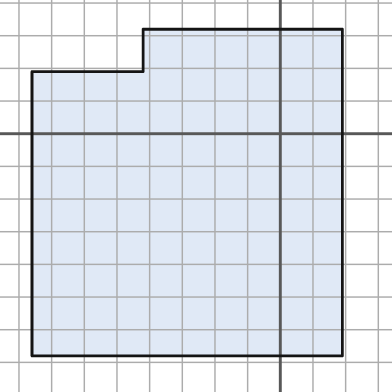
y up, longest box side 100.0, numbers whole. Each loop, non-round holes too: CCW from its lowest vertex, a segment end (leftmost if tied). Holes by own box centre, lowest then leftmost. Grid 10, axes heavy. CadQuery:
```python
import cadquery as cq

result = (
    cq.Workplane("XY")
    .moveTo(-76.0, -68.0)
    .lineTo(19.0, -68.0)
    .lineTo(19.0, 32.0)
    .lineTo(-42.0, 32.0)
    .lineTo(-42.0, 19.0)
    .lineTo(-76.0, 19.0)
    .close()
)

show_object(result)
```